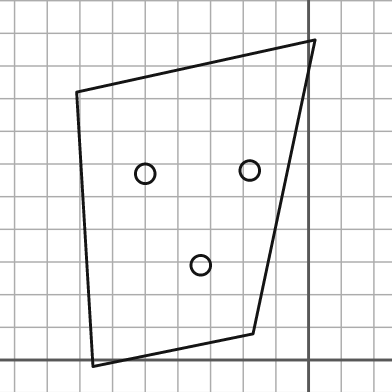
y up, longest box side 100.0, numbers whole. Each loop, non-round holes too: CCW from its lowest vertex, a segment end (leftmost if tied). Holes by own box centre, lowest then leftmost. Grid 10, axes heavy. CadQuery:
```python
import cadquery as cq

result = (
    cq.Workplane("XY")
    .moveTo(-66.0, -2.0)
    .lineTo(-17.0, 8.0)
    .lineTo(2.0, 98.0)
    .lineTo(-71.0, 82.0)
    .close()
    .moveTo(-33.0, 29.0)
    .circle(3.0)
    .moveTo(-50.0, 57.0)
    .circle(3.0)
    .moveTo(-18.0, 58.0)
    .circle(3.0)
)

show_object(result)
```